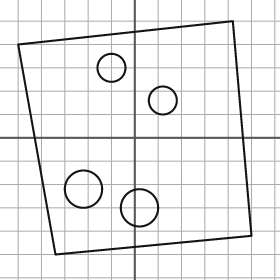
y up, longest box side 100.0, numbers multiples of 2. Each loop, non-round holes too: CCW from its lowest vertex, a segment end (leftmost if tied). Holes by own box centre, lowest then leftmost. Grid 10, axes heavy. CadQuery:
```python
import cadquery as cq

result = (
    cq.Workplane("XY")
    .moveTo(-34.0, -50.0)
    .lineTo(50.0, -42.0)
    .lineTo(42.0, 50.0)
    .lineTo(-50.0, 40.0)
    .close()
    .moveTo(2.0, -30.0)
    .circle(8.0)
    .moveTo(-22.0, -22.0)
    .circle(8.0)
    .moveTo(12.0, 16.0)
    .circle(6.0)
    .moveTo(-10.0, 30.0)
    .circle(6.0)
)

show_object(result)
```